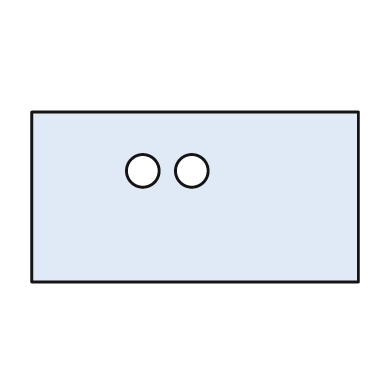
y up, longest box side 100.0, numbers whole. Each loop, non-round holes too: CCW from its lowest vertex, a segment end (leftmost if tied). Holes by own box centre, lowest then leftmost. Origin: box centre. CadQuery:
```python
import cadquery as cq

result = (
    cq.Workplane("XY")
    .moveTo(-50.0, -26.0)
    .lineTo(50.0, -26.0)
    .lineTo(50.0, 26.0)
    .lineTo(-50.0, 26.0)
    .close()
    .moveTo(-16.0, 8.0)
    .circle(5.0)
    .moveTo(-1.0, 8.0)
    .circle(5.0)
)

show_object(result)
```